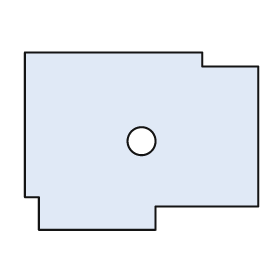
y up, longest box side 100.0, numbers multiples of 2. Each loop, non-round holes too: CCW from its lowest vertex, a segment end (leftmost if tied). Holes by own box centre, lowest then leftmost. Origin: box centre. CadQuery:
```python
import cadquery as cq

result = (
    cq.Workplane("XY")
    .moveTo(-44.0, -38.0)
    .lineTo(6.0, -38.0)
    .lineTo(6.0, -28.0)
    .lineTo(50.0, -28.0)
    .lineTo(50.0, 32.0)
    .lineTo(26.0, 32.0)
    .lineTo(26.0, 38.0)
    .lineTo(-50.0, 38.0)
    .lineTo(-50.0, -24.0)
    .lineTo(-44.0, -24.0)
    .close()
    .moveTo(0.0, 0.0)
    .circle(6.0)
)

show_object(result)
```